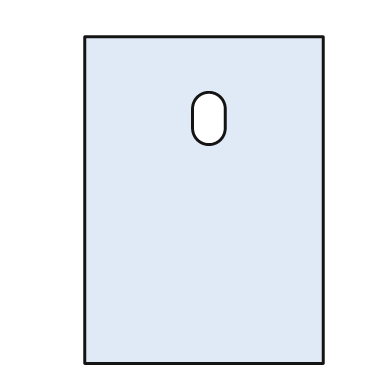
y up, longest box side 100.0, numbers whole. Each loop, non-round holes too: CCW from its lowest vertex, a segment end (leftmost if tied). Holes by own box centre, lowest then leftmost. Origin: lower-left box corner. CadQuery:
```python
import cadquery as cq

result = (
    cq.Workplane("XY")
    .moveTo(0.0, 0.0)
    .lineTo(73.0, 0.0)
    .lineTo(73.0, 100.0)
    .lineTo(0.0, 100.0)
    .close()
    .moveTo(33.0, 72.0)
    .threePointArc((38.0, 67.0), (43.0, 72.0))
    .lineTo(43.0, 78.0)
    .threePointArc((38.0, 83.0), (33.0, 78.0))
    .close()
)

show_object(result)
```